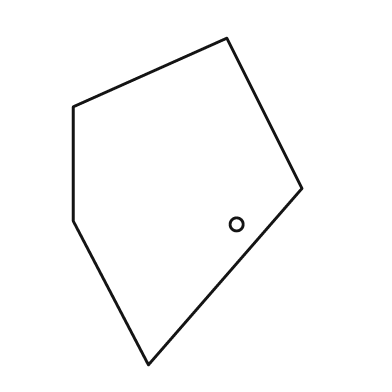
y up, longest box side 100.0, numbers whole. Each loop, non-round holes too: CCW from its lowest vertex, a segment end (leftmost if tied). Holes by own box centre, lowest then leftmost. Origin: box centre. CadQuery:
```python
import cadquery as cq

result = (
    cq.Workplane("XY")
    .moveTo(-12.0, -50.0)
    .lineTo(35.0, 4.0)
    .lineTo(12.0, 50.0)
    .lineTo(-35.0, 29.0)
    .lineTo(-35.0, -6.0)
    .close()
    .moveTo(15.0, -7.0)
    .circle(2.0)
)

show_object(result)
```